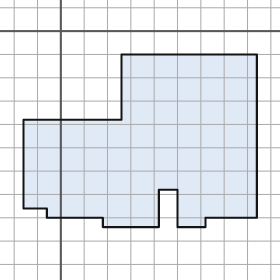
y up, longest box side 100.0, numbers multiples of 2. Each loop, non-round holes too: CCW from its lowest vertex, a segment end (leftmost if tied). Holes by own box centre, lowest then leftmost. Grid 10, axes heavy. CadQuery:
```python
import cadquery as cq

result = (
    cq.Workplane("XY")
    .moveTo(18.0, -84.0)
    .lineTo(42.0, -84.0)
    .lineTo(42.0, -68.0)
    .lineTo(50.0, -68.0)
    .lineTo(50.0, -84.0)
    .lineTo(62.0, -84.0)
    .lineTo(62.0, -80.0)
    .lineTo(84.0, -80.0)
    .lineTo(84.0, -10.0)
    .lineTo(26.0, -10.0)
    .lineTo(26.0, -38.0)
    .lineTo(-16.0, -38.0)
    .lineTo(-16.0, -76.0)
    .lineTo(-6.0, -76.0)
    .lineTo(-6.0, -80.0)
    .lineTo(18.0, -80.0)
    .close()
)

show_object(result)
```